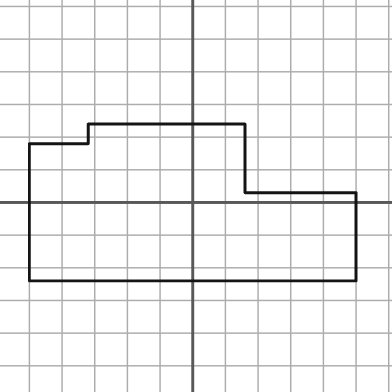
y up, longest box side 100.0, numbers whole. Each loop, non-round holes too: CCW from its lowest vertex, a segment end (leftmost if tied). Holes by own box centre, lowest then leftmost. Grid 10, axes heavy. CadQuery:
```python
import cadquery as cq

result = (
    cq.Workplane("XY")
    .moveTo(-50.0, -24.0)
    .lineTo(50.0, -24.0)
    .lineTo(50.0, 3.0)
    .lineTo(16.0, 3.0)
    .lineTo(16.0, 24.0)
    .lineTo(-32.0, 24.0)
    .lineTo(-32.0, 18.0)
    .lineTo(-50.0, 18.0)
    .close()
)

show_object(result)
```